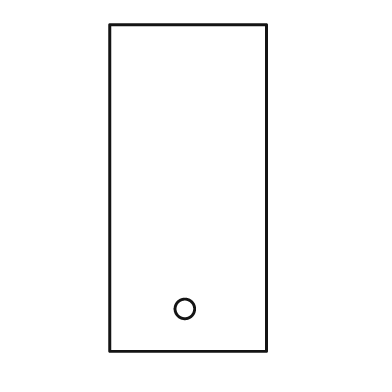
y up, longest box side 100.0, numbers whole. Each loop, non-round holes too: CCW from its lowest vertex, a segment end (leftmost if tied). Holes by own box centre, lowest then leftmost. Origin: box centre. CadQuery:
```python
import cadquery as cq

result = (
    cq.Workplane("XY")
    .moveTo(-24.0, -50.0)
    .lineTo(24.0, -50.0)
    .lineTo(24.0, 50.0)
    .lineTo(-24.0, 50.0)
    .close()
    .moveTo(-1.0, -37.0)
    .circle(3.0)
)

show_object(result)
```